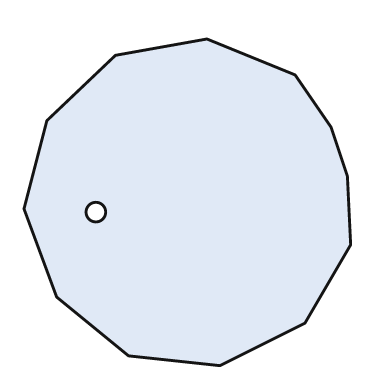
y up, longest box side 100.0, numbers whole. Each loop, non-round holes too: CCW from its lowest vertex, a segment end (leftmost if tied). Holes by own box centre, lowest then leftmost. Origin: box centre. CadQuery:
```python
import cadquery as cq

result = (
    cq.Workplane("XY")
    .moveTo(10.0, -50.0)
    .lineTo(36.0, -37.0)
    .lineTo(50.0, -13.0)
    .lineTo(49.0, 8.0)
    .lineTo(44.0, 23.0)
    .lineTo(33.0, 39.0)
    .lineTo(6.0, 50.0)
    .lineTo(-22.0, 45.0)
    .lineTo(-43.0, 25.0)
    .lineTo(-50.0, -2.0)
    .lineTo(-40.0, -29.0)
    .lineTo(-18.0, -47.0)
    .close()
    .moveTo(-28.0, -3.0)
    .circle(3.0)
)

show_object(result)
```